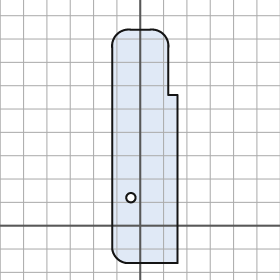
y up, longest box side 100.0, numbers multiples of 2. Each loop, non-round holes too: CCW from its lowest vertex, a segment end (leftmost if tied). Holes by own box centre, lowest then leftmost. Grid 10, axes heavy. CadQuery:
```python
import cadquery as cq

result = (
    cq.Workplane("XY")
    .moveTo(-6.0, -16.0)
    .lineTo(16.0, -16.0)
    .lineTo(16.0, 56.0)
    .lineTo(12.0, 56.0)
    .lineTo(12.0, 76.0)
    .threePointArc((10.0, 82.0), (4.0, 84.0))
    .lineTo(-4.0, 84.0)
    .threePointArc((-10.0, 82.0), (-12.0, 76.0))
    .lineTo(-12.0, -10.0)
    .threePointArc((-10.0, -14.0), (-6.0, -16.0))
    .close()
    .moveTo(-4.0, 12.0)
    .circle(2.0)
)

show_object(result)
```